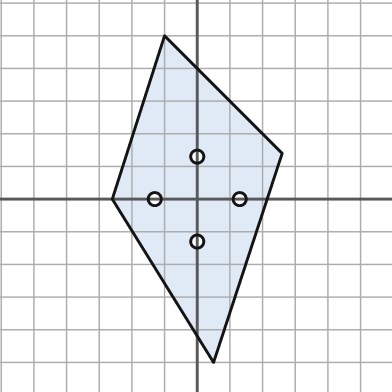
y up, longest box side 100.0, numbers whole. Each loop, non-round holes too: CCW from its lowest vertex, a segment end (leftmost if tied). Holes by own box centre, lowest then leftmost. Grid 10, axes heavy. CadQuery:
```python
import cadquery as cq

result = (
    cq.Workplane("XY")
    .moveTo(5.0, -50.0)
    .lineTo(26.0, 14.0)
    .lineTo(-10.0, 50.0)
    .lineTo(-26.0, 0.0)
    .close()
    .moveTo(0.0, -13.0)
    .circle(2.0)
    .moveTo(-13.0, 0.0)
    .circle(2.0)
    .moveTo(13.0, 0.0)
    .circle(2.0)
    .moveTo(0.0, 13.0)
    .circle(2.0)
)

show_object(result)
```